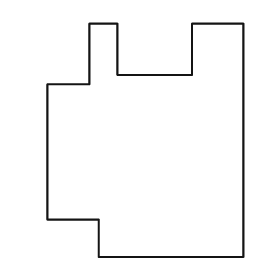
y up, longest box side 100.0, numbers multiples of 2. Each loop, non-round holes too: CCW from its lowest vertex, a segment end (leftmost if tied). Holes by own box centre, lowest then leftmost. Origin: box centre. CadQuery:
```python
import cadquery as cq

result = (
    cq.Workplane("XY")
    .moveTo(-20.0, -50.0)
    .lineTo(42.0, -50.0)
    .lineTo(42.0, 50.0)
    .lineTo(20.0, 50.0)
    .lineTo(20.0, 28.0)
    .lineTo(-12.0, 28.0)
    .lineTo(-12.0, 50.0)
    .lineTo(-24.0, 50.0)
    .lineTo(-24.0, 24.0)
    .lineTo(-42.0, 24.0)
    .lineTo(-42.0, -34.0)
    .lineTo(-20.0, -34.0)
    .close()
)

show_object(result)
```